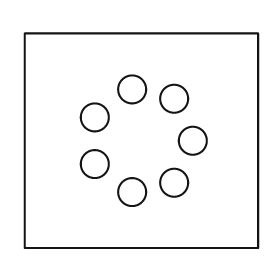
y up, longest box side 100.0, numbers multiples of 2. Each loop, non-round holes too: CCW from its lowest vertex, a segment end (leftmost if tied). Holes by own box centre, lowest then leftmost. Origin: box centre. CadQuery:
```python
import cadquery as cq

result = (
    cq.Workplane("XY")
    .moveTo(-50.0, -46.0)
    .lineTo(50.0, -46.0)
    .lineTo(50.0, 46.0)
    .lineTo(-50.0, 46.0)
    .close()
    .moveTo(-4.0, -22.0)
    .circle(6.0)
    .moveTo(14.0, -18.0)
    .circle(6.0)
    .moveTo(-20.0, -10.0)
    .circle(6.0)
    .moveTo(22.0, 0.0)
    .circle(6.0)
    .moveTo(-20.0, 10.0)
    .circle(6.0)
    .moveTo(14.0, 18.0)
    .circle(6.0)
    .moveTo(-4.0, 22.0)
    .circle(6.0)
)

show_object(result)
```